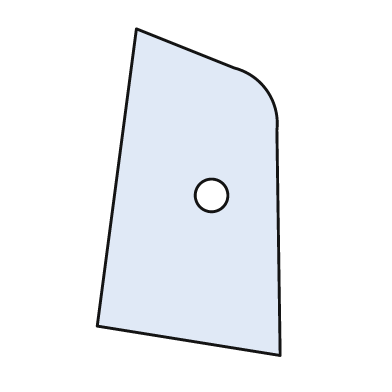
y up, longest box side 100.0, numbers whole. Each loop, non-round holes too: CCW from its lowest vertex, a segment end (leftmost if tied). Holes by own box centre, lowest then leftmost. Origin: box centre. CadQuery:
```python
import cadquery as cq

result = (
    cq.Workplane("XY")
    .moveTo(28.0, -50.0)
    .lineTo(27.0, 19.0)
    .threePointArc((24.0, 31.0), (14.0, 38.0))
    .lineTo(-16.0, 50.0)
    .lineTo(-28.0, -41.0)
    .close()
    .moveTo(7.0, -1.0)
    .circle(5.0)
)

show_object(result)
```